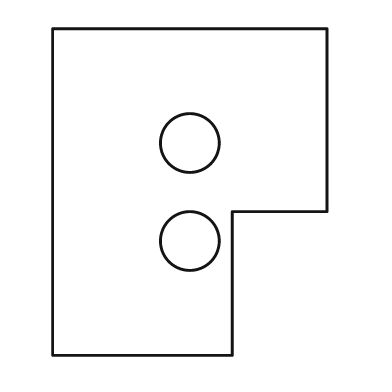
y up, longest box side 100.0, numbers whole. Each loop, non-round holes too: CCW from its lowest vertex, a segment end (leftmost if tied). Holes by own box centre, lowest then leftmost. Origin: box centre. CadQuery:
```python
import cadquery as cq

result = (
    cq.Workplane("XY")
    .moveTo(-42.0, -50.0)
    .lineTo(13.0, -50.0)
    .lineTo(13.0, -6.0)
    .lineTo(42.0, -6.0)
    .lineTo(42.0, 50.0)
    .lineTo(-42.0, 50.0)
    .close()
    .moveTo(0.0, -15.0)
    .circle(9.0)
    .moveTo(0.0, 15.0)
    .circle(9.0)
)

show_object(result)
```